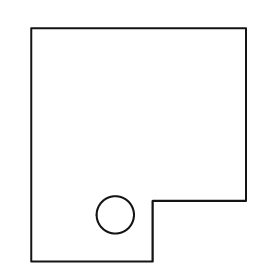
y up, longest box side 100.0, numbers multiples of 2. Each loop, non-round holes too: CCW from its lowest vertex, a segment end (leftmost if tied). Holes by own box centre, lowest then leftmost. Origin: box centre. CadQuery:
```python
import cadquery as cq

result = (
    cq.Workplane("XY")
    .moveTo(-46.0, -50.0)
    .lineTo(6.0, -50.0)
    .lineTo(6.0, -24.0)
    .lineTo(46.0, -24.0)
    .lineTo(46.0, 50.0)
    .lineTo(-46.0, 50.0)
    .close()
    .moveTo(-10.0, -30.0)
    .circle(8.0)
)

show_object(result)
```